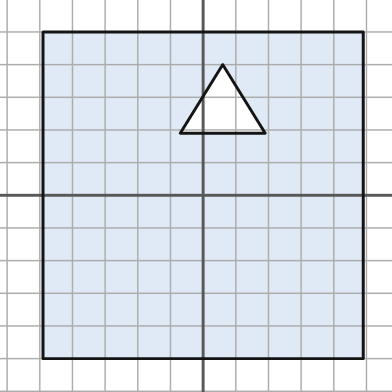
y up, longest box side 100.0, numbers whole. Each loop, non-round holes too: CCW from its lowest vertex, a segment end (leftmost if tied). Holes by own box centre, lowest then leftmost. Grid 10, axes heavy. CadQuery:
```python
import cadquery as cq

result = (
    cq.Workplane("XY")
    .moveTo(-49.0, -50.0)
    .lineTo(49.0, -50.0)
    .lineTo(49.0, 50.0)
    .lineTo(-49.0, 50.0)
    .close()
    .moveTo(-7.0, 19.0)
    .lineTo(19.0, 19.0)
    .lineTo(6.0, 40.0)
    .close()
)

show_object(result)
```